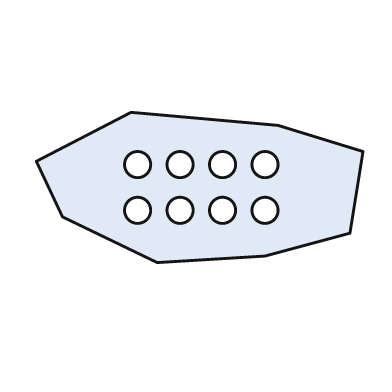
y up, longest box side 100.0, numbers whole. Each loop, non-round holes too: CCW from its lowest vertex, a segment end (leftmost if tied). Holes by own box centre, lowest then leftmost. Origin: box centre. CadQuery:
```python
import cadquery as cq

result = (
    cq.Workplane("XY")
    .moveTo(-13.0, -23.0)
    .lineTo(20.0, -21.0)
    .lineTo(46.0, -14.0)
    .lineTo(50.0, 11.0)
    .lineTo(24.0, 19.0)
    .lineTo(-21.0, 23.0)
    .lineTo(-50.0, 8.0)
    .lineTo(-42.0, -9.0)
    .close()
    .moveTo(-19.0, -7.0)
    .circle(4.0)
    .moveTo(-6.0, -7.0)
    .circle(4.0)
    .moveTo(7.0, -7.0)
    .circle(4.0)
    .moveTo(20.0, -7.0)
    .circle(4.0)
    .moveTo(-19.0, 7.0)
    .circle(4.0)
    .moveTo(-6.0, 7.0)
    .circle(4.0)
    .moveTo(7.0, 7.0)
    .circle(4.0)
    .moveTo(20.0, 7.0)
    .circle(4.0)
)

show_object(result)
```